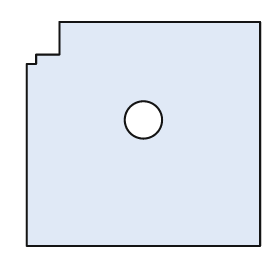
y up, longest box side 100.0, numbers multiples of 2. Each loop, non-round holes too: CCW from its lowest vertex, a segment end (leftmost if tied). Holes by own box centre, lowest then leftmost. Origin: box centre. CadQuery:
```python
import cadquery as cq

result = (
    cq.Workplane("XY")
    .moveTo(-50.0, -48.0)
    .lineTo(50.0, -48.0)
    .lineTo(50.0, 48.0)
    .lineTo(-36.0, 48.0)
    .lineTo(-36.0, 34.0)
    .lineTo(-46.0, 34.0)
    .lineTo(-46.0, 30.0)
    .lineTo(-50.0, 30.0)
    .close()
    .moveTo(0.0, 6.0)
    .circle(8.0)
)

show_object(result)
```